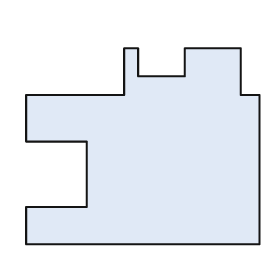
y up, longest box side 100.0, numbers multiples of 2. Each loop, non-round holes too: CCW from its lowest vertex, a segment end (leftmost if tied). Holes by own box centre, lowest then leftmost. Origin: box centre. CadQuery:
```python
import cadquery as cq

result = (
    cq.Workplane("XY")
    .moveTo(-50.0, -42.0)
    .lineTo(50.0, -42.0)
    .lineTo(50.0, 22.0)
    .lineTo(42.0, 22.0)
    .lineTo(42.0, 42.0)
    .lineTo(18.0, 42.0)
    .lineTo(18.0, 30.0)
    .lineTo(-2.0, 30.0)
    .lineTo(-2.0, 42.0)
    .lineTo(-8.0, 42.0)
    .lineTo(-8.0, 22.0)
    .lineTo(-50.0, 22.0)
    .lineTo(-50.0, 2.0)
    .lineTo(-24.0, 2.0)
    .lineTo(-24.0, -26.0)
    .lineTo(-50.0, -26.0)
    .close()
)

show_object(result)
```